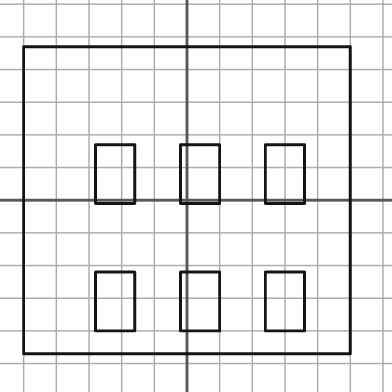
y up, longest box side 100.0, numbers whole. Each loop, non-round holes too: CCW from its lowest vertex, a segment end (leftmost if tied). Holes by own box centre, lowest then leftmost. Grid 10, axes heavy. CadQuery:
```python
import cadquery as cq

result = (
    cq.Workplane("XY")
    .moveTo(-50.0, -47.0)
    .lineTo(50.0, -47.0)
    .lineTo(50.0, 47.0)
    .lineTo(-50.0, 47.0)
    .close()
    .moveTo(-28.0, -40.0)
    .lineTo(-16.0, -40.0)
    .lineTo(-16.0, -22.0)
    .lineTo(-28.0, -22.0)
    .close()
    .moveTo(-2.0, -40.0)
    .lineTo(10.0, -40.0)
    .lineTo(10.0, -22.0)
    .lineTo(-2.0, -22.0)
    .close()
    .moveTo(24.0, -40.0)
    .lineTo(36.0, -40.0)
    .lineTo(36.0, -22.0)
    .lineTo(24.0, -22.0)
    .close()
    .moveTo(-28.0, -1.0)
    .lineTo(-16.0, -1.0)
    .lineTo(-16.0, 17.0)
    .lineTo(-28.0, 17.0)
    .close()
    .moveTo(-2.0, -1.0)
    .lineTo(10.0, -1.0)
    .lineTo(10.0, 17.0)
    .lineTo(-2.0, 17.0)
    .close()
    .moveTo(24.0, -1.0)
    .lineTo(36.0, -1.0)
    .lineTo(36.0, 17.0)
    .lineTo(24.0, 17.0)
    .close()
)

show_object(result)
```